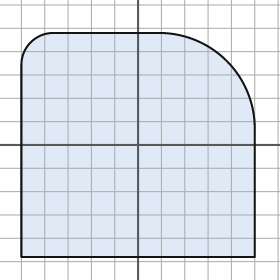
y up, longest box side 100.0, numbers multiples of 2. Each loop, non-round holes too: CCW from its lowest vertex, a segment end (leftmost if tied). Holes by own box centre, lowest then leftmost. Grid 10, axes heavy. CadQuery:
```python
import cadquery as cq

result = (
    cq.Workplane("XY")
    .moveTo(-50.0, -48.0)
    .lineTo(50.0, -48.0)
    .lineTo(50.0, 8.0)
    .threePointArc((38.0, 36.0), (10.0, 48.0))
    .lineTo(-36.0, 48.0)
    .threePointArc((-46.0, 44.0), (-50.0, 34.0))
    .close()
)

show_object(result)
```